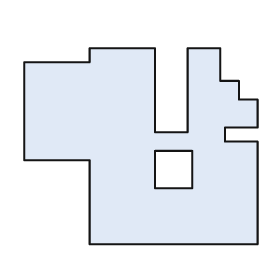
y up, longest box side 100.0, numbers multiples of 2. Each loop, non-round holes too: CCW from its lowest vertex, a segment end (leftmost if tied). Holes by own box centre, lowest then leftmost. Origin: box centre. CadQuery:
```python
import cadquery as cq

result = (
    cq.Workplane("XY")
    .moveTo(-22.0, -42.0)
    .lineTo(50.0, -42.0)
    .lineTo(50.0, 2.0)
    .lineTo(36.0, 2.0)
    .lineTo(36.0, 8.0)
    .lineTo(50.0, 8.0)
    .lineTo(50.0, 20.0)
    .lineTo(42.0, 20.0)
    .lineTo(42.0, 28.0)
    .lineTo(34.0, 28.0)
    .lineTo(34.0, 42.0)
    .lineTo(20.0, 42.0)
    .lineTo(20.0, 6.0)
    .lineTo(6.0, 6.0)
    .lineTo(6.0, 42.0)
    .lineTo(-22.0, 42.0)
    .lineTo(-22.0, 36.0)
    .lineTo(-50.0, 36.0)
    .lineTo(-50.0, -6.0)
    .lineTo(-22.0, -6.0)
    .close()
    .moveTo(6.0, -18.0)
    .lineTo(22.0, -18.0)
    .lineTo(22.0, -2.0)
    .lineTo(6.0, -2.0)
    .close()
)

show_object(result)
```